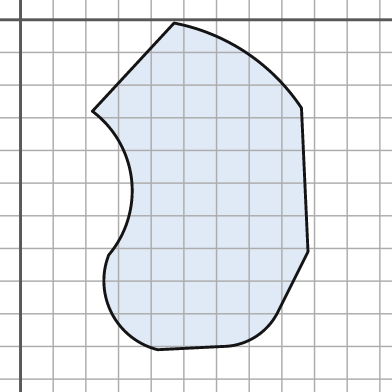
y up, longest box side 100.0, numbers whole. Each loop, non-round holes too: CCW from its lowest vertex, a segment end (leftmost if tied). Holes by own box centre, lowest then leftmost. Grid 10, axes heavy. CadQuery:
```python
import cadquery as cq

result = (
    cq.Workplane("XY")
    .moveTo(42.0, -101.0)
    .lineTo(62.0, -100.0)
    .threePointArc((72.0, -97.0), (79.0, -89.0))
    .lineTo(88.0, -71.0)
    .lineTo(86.0, -27.0)
    .threePointArc((69.0, -10.0), (47.0, -1.0))
    .lineTo(22.0, -28.0)
    .threePointArc((34.0, -49.0), (27.0, -72.0))
    .threePointArc((28.0, -90.0), (42.0, -101.0))
    .close()
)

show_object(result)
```